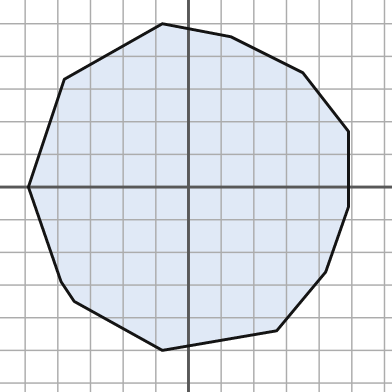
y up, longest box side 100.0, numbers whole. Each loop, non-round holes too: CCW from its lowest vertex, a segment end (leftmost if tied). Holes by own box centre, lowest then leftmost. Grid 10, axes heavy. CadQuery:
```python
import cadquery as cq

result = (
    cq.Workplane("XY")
    .moveTo(-8.0, -50.0)
    .lineTo(27.0, -44.0)
    .lineTo(42.0, -26.0)
    .lineTo(49.0, -6.0)
    .lineTo(49.0, 17.0)
    .lineTo(35.0, 35.0)
    .lineTo(13.0, 46.0)
    .lineTo(-8.0, 50.0)
    .lineTo(-38.0, 33.0)
    .lineTo(-49.0, 0.0)
    .lineTo(-39.0, -29.0)
    .lineTo(-35.0, -35.0)
    .close()
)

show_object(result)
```